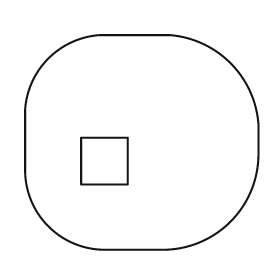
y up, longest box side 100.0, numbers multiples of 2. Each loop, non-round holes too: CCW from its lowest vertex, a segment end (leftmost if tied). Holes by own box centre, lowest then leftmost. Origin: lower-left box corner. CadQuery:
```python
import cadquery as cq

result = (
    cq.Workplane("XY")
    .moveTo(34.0, 0.0)
    .lineTo(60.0, 0.0)
    .threePointArc((88.0, 12.0), (100.0, 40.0))
    .lineTo(100.0, 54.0)
    .threePointArc((88.0, 80.0), (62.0, 92.0))
    .lineTo(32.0, 92.0)
    .threePointArc((10.0, 82.0), (0.0, 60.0))
    .lineTo(0.0, 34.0)
    .threePointArc((10.0, 10.0), (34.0, 0.0))
    .close()
    .moveTo(24.0, 28.0)
    .lineTo(44.0, 28.0)
    .lineTo(44.0, 48.0)
    .lineTo(24.0, 48.0)
    .close()
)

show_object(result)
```